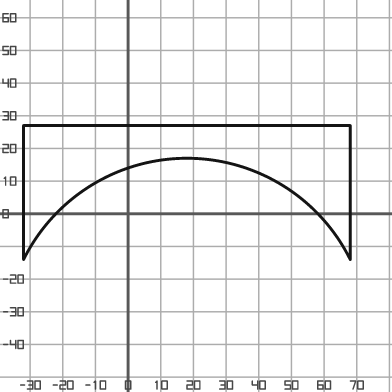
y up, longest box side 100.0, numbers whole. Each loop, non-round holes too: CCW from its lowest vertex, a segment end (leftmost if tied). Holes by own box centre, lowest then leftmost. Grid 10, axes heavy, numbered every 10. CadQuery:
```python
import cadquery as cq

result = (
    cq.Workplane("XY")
    .moveTo(-32.0, -14.0)
    .threePointArc((18.0, 17.0), (68.0, -14.0))
    .lineTo(68.0, 27.0)
    .lineTo(-32.0, 27.0)
    .close()
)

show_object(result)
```